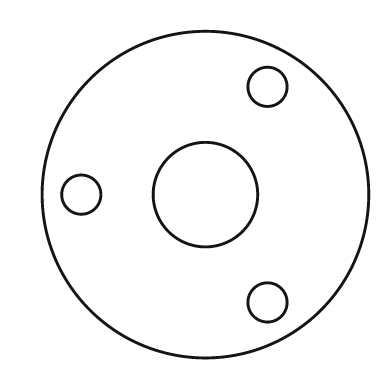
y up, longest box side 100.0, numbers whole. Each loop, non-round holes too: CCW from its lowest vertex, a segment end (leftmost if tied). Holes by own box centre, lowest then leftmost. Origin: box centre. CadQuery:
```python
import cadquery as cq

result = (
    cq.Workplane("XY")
    .moveTo(0.0, 0.0)
    .circle(50.0)
    .moveTo(19.0, -33.0)
    .circle(6.0)
    .moveTo(-38.0, 0.0)
    .circle(6.0)
    .moveTo(0.0, 0.0)
    .circle(16.0)
    .moveTo(19.0, 33.0)
    .circle(6.0)
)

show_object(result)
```